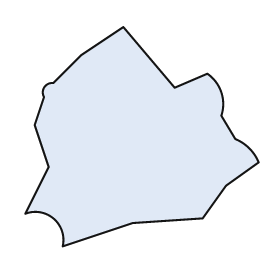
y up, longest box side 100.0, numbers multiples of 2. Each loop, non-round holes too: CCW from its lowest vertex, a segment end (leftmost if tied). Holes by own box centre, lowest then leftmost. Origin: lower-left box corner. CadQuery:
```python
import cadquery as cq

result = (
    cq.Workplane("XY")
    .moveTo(16.0, 0.0)
    .lineTo(46.0, 10.0)
    .lineTo(76.0, 12.0)
    .lineTo(86.0, 26.0)
    .lineTo(100.0, 36.0)
    .threePointArc((96.0, 42.0), (90.0, 46.0))
    .lineTo(84.0, 56.0)
    .threePointArc((84.0, 66.0), (78.0, 74.0))
    .lineTo(64.0, 68.0)
    .lineTo(42.0, 94.0)
    .lineTo(24.0, 82.0)
    .lineTo(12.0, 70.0)
    .threePointArc((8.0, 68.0), (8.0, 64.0))
    .lineTo(4.0, 52.0)
    .lineTo(10.0, 34.0)
    .lineTo(0.0, 14.0)
    .threePointArc((12.0, 12.0), (16.0, 0.0))
    .close()
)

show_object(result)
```